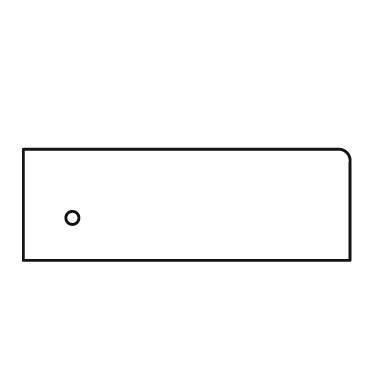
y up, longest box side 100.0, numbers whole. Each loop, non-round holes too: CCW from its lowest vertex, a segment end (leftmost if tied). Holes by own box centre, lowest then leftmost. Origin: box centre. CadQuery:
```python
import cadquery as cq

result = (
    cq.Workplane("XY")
    .moveTo(-50.0, -17.0)
    .lineTo(50.0, -17.0)
    .lineTo(50.0, 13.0)
    .threePointArc((49.0, 16.0), (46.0, 17.0))
    .lineTo(-50.0, 17.0)
    .close()
    .moveTo(-35.0, -4.0)
    .circle(2.0)
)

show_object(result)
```